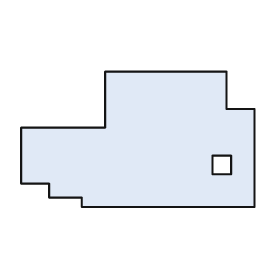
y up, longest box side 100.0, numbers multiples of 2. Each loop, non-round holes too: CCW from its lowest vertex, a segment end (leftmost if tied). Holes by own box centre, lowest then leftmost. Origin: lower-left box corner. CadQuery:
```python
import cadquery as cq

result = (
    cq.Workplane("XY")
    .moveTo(26.0, 0.0)
    .lineTo(100.0, 0.0)
    .lineTo(100.0, 42.0)
    .lineTo(88.0, 42.0)
    .lineTo(88.0, 58.0)
    .lineTo(36.0, 58.0)
    .lineTo(36.0, 34.0)
    .lineTo(0.0, 34.0)
    .lineTo(0.0, 10.0)
    .lineTo(12.0, 10.0)
    .lineTo(12.0, 4.0)
    .lineTo(26.0, 4.0)
    .close()
    .moveTo(82.0, 14.0)
    .lineTo(90.0, 14.0)
    .lineTo(90.0, 22.0)
    .lineTo(82.0, 22.0)
    .close()
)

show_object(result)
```